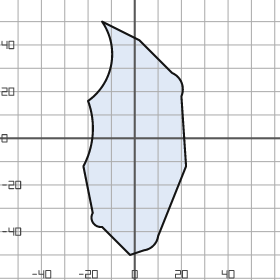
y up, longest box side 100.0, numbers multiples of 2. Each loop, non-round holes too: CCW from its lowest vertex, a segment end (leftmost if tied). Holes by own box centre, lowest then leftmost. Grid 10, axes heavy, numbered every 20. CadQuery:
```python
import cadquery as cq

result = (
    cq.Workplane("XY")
    .moveTo(-2.0, -50.0)
    .lineTo(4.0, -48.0)
    .threePointArc((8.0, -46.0), (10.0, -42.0))
    .lineTo(22.0, -12.0)
    .lineTo(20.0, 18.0)
    .threePointArc((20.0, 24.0), (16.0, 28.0))
    .lineTo(2.0, 42.0)
    .lineTo(-14.0, 50.0)
    .threePointArc((-10.0, 32.0), (-20.0, 16.0))
    .threePointArc((-18.0, 2.0), (-22.0, -12.0))
    .lineTo(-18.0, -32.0)
    .threePointArc((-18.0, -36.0), (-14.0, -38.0))
    .close()
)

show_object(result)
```